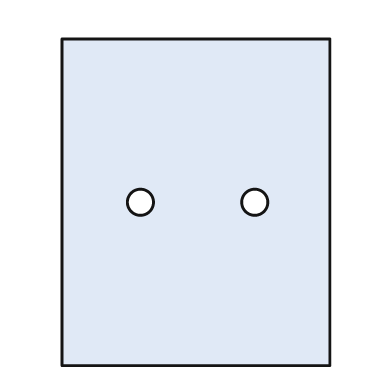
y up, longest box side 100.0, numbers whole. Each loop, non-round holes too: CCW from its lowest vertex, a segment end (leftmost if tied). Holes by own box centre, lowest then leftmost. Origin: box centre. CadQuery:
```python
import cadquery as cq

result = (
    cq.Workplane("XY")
    .moveTo(-41.0, -50.0)
    .lineTo(41.0, -50.0)
    .lineTo(41.0, 50.0)
    .lineTo(-41.0, 50.0)
    .close()
    .moveTo(-17.0, 0.0)
    .circle(4.0)
    .moveTo(18.0, 0.0)
    .circle(4.0)
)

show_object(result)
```